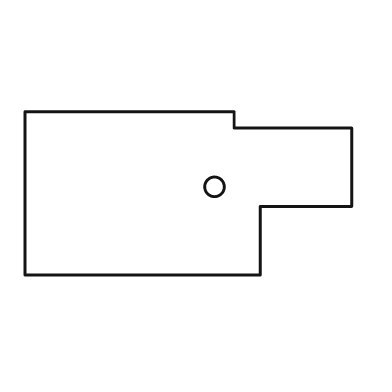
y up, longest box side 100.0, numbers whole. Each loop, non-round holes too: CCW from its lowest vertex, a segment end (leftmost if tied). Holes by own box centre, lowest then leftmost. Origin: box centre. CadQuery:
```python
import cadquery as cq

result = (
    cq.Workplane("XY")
    .moveTo(-50.0, -25.0)
    .lineTo(22.0, -25.0)
    .lineTo(22.0, -4.0)
    .lineTo(50.0, -4.0)
    .lineTo(50.0, 20.0)
    .lineTo(14.0, 20.0)
    .lineTo(14.0, 25.0)
    .lineTo(-50.0, 25.0)
    .close()
    .moveTo(8.0, 2.0)
    .circle(3.0)
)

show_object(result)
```